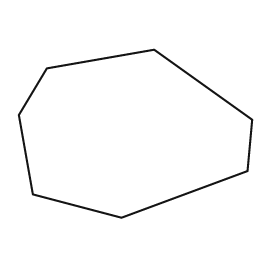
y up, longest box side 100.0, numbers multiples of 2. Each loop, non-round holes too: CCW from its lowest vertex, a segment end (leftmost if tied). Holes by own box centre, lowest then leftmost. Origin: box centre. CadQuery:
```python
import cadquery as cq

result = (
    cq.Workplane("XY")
    .moveTo(-6.0, -36.0)
    .lineTo(48.0, -16.0)
    .lineTo(50.0, 6.0)
    .lineTo(8.0, 36.0)
    .lineTo(-38.0, 28.0)
    .lineTo(-50.0, 8.0)
    .lineTo(-44.0, -26.0)
    .close()
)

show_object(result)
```